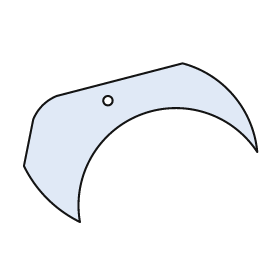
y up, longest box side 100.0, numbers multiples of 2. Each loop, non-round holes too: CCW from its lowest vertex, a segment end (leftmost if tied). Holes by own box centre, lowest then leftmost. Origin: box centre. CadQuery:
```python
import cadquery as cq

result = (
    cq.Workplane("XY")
    .moveTo(-26.0, -34.0)
    .threePointArc((0.0, 12.0), (50.0, -4.0))
    .threePointArc((40.0, 20.0), (18.0, 34.0))
    .lineTo(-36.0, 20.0)
    .threePointArc((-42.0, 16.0), (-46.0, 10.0))
    .lineTo(-50.0, -10.0)
    .threePointArc((-40.0, -24.0), (-26.0, -34.0))
    .close()
    .moveTo(-14.0, 18.0)
    .circle(2.0)
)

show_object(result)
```